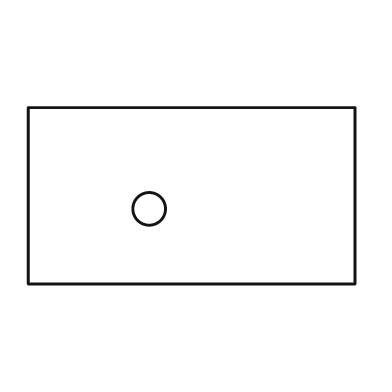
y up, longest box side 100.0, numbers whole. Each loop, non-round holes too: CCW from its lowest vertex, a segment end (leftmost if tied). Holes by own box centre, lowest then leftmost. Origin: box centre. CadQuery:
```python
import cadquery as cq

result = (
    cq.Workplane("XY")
    .moveTo(-50.0, -27.0)
    .lineTo(50.0, -27.0)
    .lineTo(50.0, 27.0)
    .lineTo(-50.0, 27.0)
    .close()
    .moveTo(-13.0, -4.0)
    .circle(5.0)
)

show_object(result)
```